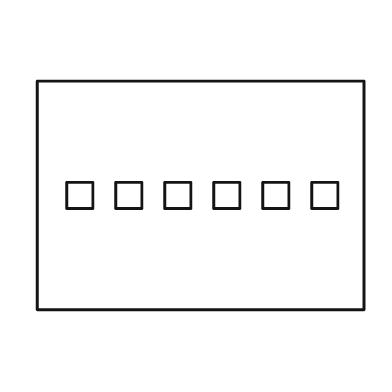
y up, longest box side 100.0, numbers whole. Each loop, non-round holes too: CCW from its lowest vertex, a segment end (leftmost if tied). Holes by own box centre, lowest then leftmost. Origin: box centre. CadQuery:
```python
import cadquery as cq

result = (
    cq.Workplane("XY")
    .moveTo(-50.0, -35.0)
    .lineTo(50.0, -35.0)
    .lineTo(50.0, 35.0)
    .lineTo(-50.0, 35.0)
    .close()
    .moveTo(-41.0, -4.0)
    .lineTo(-33.0, -4.0)
    .lineTo(-33.0, 4.0)
    .lineTo(-41.0, 4.0)
    .close()
    .moveTo(-26.0, -4.0)
    .lineTo(-18.0, -4.0)
    .lineTo(-18.0, 4.0)
    .lineTo(-26.0, 4.0)
    .close()
    .moveTo(-11.0, -4.0)
    .lineTo(-3.0, -4.0)
    .lineTo(-3.0, 4.0)
    .lineTo(-11.0, 4.0)
    .close()
    .moveTo(4.0, -4.0)
    .lineTo(12.0, -4.0)
    .lineTo(12.0, 4.0)
    .lineTo(4.0, 4.0)
    .close()
    .moveTo(19.0, -4.0)
    .lineTo(27.0, -4.0)
    .lineTo(27.0, 4.0)
    .lineTo(19.0, 4.0)
    .close()
    .moveTo(34.0, -4.0)
    .lineTo(42.0, -4.0)
    .lineTo(42.0, 4.0)
    .lineTo(34.0, 4.0)
    .close()
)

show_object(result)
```